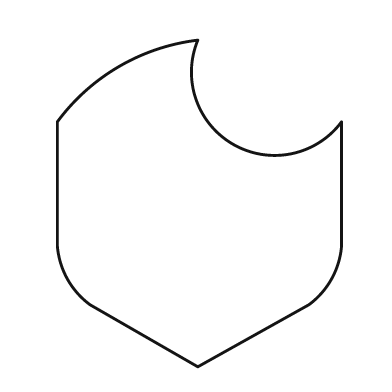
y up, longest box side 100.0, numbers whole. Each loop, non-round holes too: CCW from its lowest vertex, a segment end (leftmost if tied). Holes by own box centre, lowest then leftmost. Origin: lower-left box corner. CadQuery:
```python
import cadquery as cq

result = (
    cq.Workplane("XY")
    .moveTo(43.0, 0.0)
    .lineTo(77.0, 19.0)
    .threePointArc((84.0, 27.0), (87.0, 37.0))
    .lineTo(87.0, 75.0)
    .threePointArc((54.0, 68.0), (43.0, 100.0))
    .threePointArc((19.0, 92.0), (0.0, 75.0))
    .lineTo(0.0, 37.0)
    .threePointArc((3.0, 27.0), (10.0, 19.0))
    .close()
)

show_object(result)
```